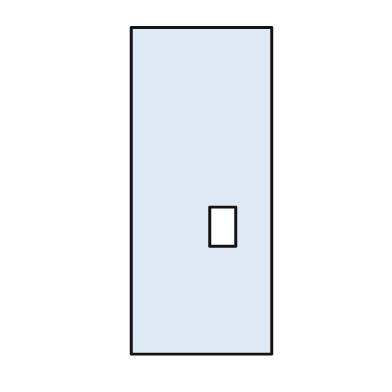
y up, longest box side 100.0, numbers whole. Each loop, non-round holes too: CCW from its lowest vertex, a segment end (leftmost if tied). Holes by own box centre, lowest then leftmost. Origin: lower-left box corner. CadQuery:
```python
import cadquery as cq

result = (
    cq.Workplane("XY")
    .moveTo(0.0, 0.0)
    .lineTo(43.0, 0.0)
    .lineTo(43.0, 100.0)
    .lineTo(0.0, 100.0)
    .close()
    .moveTo(24.0, 33.0)
    .lineTo(32.0, 33.0)
    .lineTo(32.0, 45.0)
    .lineTo(24.0, 45.0)
    .close()
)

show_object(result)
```